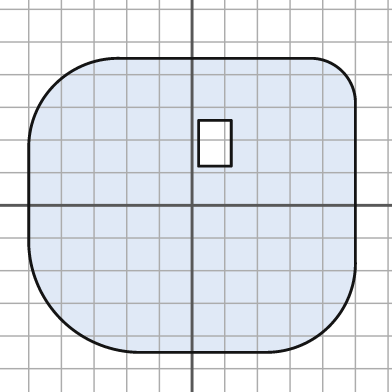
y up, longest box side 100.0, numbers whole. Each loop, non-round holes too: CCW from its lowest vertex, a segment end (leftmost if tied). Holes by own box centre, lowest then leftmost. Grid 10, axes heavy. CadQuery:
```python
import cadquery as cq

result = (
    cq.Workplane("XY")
    .moveTo(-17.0, -45.0)
    .lineTo(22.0, -45.0)
    .threePointArc((42.0, -37.0), (50.0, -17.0))
    .lineTo(50.0, 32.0)
    .threePointArc((46.0, 41.0), (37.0, 45.0))
    .lineTo(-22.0, 45.0)
    .threePointArc((-42.0, 37.0), (-50.0, 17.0))
    .lineTo(-50.0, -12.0)
    .threePointArc((-40.0, -35.0), (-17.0, -45.0))
    .close()
    .moveTo(2.0, 12.0)
    .lineTo(12.0, 12.0)
    .lineTo(12.0, 26.0)
    .lineTo(2.0, 26.0)
    .close()
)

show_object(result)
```